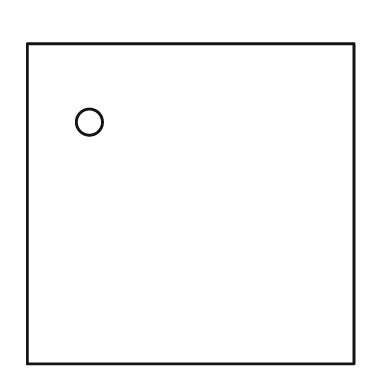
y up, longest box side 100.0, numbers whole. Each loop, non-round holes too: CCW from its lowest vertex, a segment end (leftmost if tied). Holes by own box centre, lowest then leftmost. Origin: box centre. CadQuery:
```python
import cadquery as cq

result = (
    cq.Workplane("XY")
    .moveTo(-50.0, -49.0)
    .lineTo(50.0, -49.0)
    .lineTo(50.0, 49.0)
    .lineTo(-50.0, 49.0)
    .close()
    .moveTo(-31.0, 25.0)
    .circle(4.0)
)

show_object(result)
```